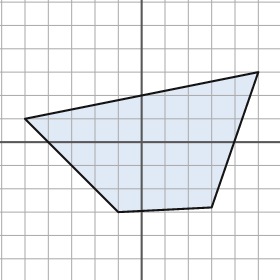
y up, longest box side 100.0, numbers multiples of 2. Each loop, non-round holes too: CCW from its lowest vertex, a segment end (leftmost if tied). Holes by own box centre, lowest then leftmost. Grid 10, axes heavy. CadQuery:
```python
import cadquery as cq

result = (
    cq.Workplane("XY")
    .moveTo(-10.0, -30.0)
    .lineTo(30.0, -28.0)
    .lineTo(50.0, 30.0)
    .lineTo(-50.0, 10.0)
    .close()
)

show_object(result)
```